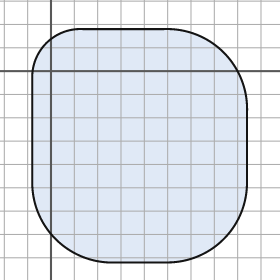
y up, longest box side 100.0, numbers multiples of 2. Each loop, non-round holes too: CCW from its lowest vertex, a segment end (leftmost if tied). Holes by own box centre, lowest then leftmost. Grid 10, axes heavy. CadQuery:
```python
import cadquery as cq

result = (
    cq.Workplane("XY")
    .moveTo(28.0, -82.0)
    .lineTo(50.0, -82.0)
    .threePointArc((74.0, -72.0), (84.0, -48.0))
    .lineTo(84.0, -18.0)
    .threePointArc((74.0, 8.0), (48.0, 18.0))
    .lineTo(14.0, 18.0)
    .threePointArc((-2.0, 12.0), (-8.0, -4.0))
    .lineTo(-8.0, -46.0)
    .threePointArc((2.0, -72.0), (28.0, -82.0))
    .close()
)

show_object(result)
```